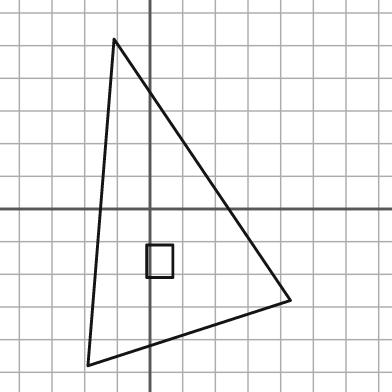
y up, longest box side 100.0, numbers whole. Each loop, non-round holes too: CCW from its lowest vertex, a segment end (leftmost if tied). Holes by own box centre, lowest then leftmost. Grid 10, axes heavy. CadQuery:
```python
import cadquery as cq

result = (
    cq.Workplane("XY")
    .moveTo(-19.0, -48.0)
    .lineTo(43.0, -28.0)
    .lineTo(-11.0, 52.0)
    .close()
    .moveTo(-1.0, -21.0)
    .lineTo(7.0, -21.0)
    .lineTo(7.0, -11.0)
    .lineTo(-1.0, -11.0)
    .close()
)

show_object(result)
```